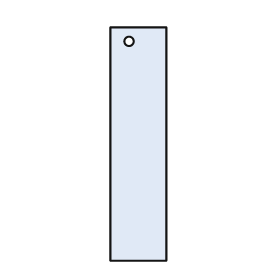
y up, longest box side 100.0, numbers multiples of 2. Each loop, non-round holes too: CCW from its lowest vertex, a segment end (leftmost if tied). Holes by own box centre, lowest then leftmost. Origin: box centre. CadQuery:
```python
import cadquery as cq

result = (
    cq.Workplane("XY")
    .moveTo(-12.0, -50.0)
    .lineTo(12.0, -50.0)
    .lineTo(12.0, 50.0)
    .lineTo(-12.0, 50.0)
    .close()
    .moveTo(-4.0, 44.0)
    .circle(2.0)
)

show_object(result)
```